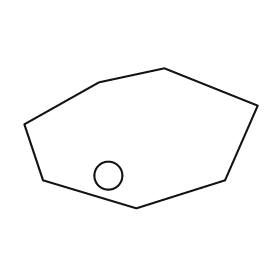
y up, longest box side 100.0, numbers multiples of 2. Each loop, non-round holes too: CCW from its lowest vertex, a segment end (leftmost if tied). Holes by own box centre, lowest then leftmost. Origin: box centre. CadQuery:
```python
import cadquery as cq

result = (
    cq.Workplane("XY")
    .moveTo(-2.0, -30.0)
    .lineTo(36.0, -18.0)
    .lineTo(50.0, 14.0)
    .lineTo(10.0, 30.0)
    .lineTo(-18.0, 24.0)
    .lineTo(-50.0, 6.0)
    .lineTo(-42.0, -18.0)
    .close()
    .moveTo(-14.0, -16.0)
    .circle(6.0)
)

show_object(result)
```